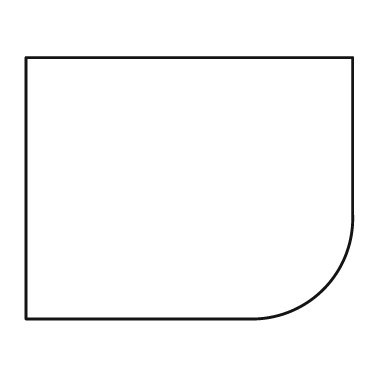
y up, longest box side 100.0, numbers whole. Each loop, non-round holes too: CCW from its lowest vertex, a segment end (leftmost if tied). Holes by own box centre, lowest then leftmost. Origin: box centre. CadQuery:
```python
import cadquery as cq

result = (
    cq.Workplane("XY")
    .moveTo(-50.0, -40.0)
    .lineTo(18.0, -40.0)
    .threePointArc((41.0, -31.0), (50.0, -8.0))
    .lineTo(50.0, 40.0)
    .lineTo(-50.0, 40.0)
    .close()
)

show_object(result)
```